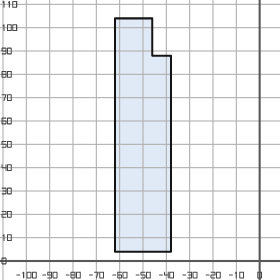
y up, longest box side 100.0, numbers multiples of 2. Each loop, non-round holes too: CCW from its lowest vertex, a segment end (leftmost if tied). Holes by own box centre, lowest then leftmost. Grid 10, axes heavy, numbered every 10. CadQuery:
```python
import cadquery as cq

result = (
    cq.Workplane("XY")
    .moveTo(-62.0, 4.0)
    .lineTo(-38.0, 4.0)
    .lineTo(-38.0, 88.0)
    .lineTo(-46.0, 88.0)
    .lineTo(-46.0, 104.0)
    .lineTo(-62.0, 104.0)
    .close()
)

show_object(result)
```